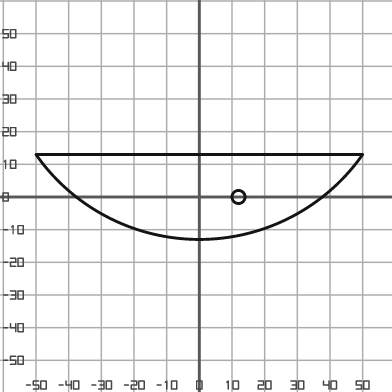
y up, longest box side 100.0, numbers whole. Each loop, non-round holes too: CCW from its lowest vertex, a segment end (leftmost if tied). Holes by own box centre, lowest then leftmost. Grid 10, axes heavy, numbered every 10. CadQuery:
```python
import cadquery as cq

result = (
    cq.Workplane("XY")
    .moveTo(-50.0, 13.0)
    .threePointArc((0.0, -13.0), (50.0, 13.0))
    .close()
    .moveTo(12.0, 0.0)
    .circle(2.0)
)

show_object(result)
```